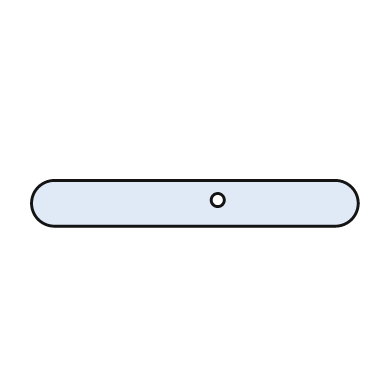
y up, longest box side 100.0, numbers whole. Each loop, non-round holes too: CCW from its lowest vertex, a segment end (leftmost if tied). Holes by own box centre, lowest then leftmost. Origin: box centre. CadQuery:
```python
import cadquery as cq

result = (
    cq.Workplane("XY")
    .moveTo(-43.0, -7.0)
    .lineTo(43.0, -7.0)
    .threePointArc((50.0, 0.0), (43.0, 7.0))
    .lineTo(-43.0, 7.0)
    .threePointArc((-50.0, 0.0), (-43.0, -7.0))
    .close()
    .moveTo(7.0, 1.0)
    .circle(2.0)
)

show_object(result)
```